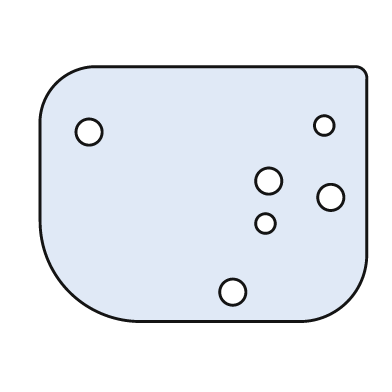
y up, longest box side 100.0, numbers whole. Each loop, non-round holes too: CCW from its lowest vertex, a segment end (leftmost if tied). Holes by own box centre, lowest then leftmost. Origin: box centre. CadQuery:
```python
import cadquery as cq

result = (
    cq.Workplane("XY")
    .moveTo(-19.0, -39.0)
    .lineTo(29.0, -39.0)
    .threePointArc((44.0, -33.0), (50.0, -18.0))
    .lineTo(50.0, 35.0)
    .threePointArc((49.0, 38.0), (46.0, 39.0))
    .lineTo(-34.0, 39.0)
    .threePointArc((-45.0, 34.0), (-50.0, 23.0))
    .lineTo(-50.0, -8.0)
    .threePointArc((-41.0, -30.0), (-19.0, -39.0))
    .close()
    .moveTo(9.0, -30.0)
    .circle(4.0)
    .moveTo(19.0, -9.0)
    .circle(3.0)
    .moveTo(39.0, -1.0)
    .circle(4.0)
    .moveTo(20.0, 4.0)
    .circle(4.0)
    .moveTo(-35.0, 19.0)
    .circle(4.0)
    .moveTo(37.0, 21.0)
    .circle(3.0)
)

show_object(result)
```